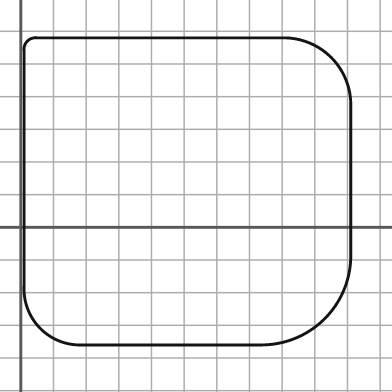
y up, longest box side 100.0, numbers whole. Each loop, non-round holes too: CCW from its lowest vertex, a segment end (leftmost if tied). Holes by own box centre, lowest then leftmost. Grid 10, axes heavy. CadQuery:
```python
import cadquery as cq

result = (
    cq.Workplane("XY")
    .moveTo(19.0, -36.0)
    .lineTo(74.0, -36.0)
    .threePointArc((93.0, -28.0), (101.0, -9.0))
    .lineTo(101.0, 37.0)
    .threePointArc((95.0, 52.0), (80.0, 58.0))
    .lineTo(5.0, 58.0)
    .threePointArc((2.0, 57.0), (1.0, 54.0))
    .lineTo(1.0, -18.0)
    .threePointArc((6.0, -31.0), (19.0, -36.0))
    .close()
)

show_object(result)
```